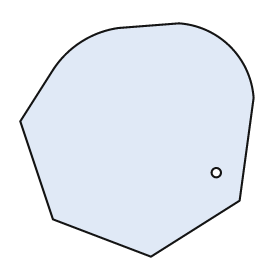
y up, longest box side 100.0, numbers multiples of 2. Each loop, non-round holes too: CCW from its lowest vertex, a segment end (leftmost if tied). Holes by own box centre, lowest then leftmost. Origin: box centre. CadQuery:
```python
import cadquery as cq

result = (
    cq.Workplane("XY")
    .moveTo(6.0, -50.0)
    .lineTo(44.0, -26.0)
    .lineTo(50.0, 18.0)
    .threePointArc((40.0, 40.0), (18.0, 50.0))
    .lineTo(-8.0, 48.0)
    .threePointArc((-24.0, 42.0), (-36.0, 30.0))
    .lineTo(-50.0, 8.0)
    .lineTo(-36.0, -34.0)
    .close()
    .moveTo(34.0, -14.0)
    .circle(2.0)
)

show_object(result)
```